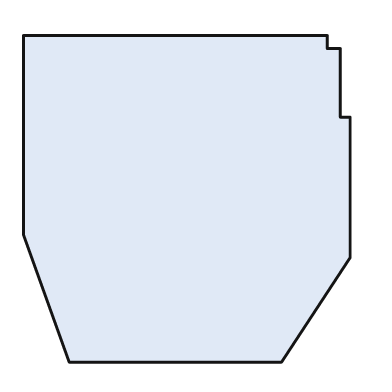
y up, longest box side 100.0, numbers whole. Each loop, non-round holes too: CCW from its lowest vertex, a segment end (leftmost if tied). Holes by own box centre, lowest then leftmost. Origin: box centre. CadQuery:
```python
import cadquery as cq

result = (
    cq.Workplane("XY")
    .moveTo(-36.0, -50.0)
    .lineTo(29.0, -50.0)
    .lineTo(50.0, -18.0)
    .lineTo(50.0, 25.0)
    .lineTo(47.0, 25.0)
    .lineTo(47.0, 46.0)
    .lineTo(43.0, 46.0)
    .lineTo(43.0, 50.0)
    .lineTo(-50.0, 50.0)
    .lineTo(-50.0, -11.0)
    .close()
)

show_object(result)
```